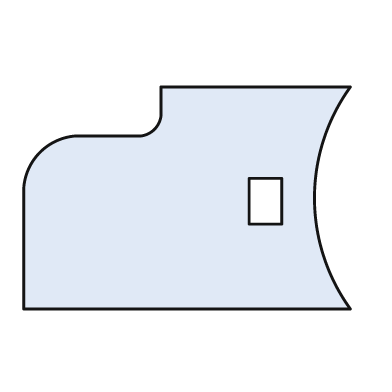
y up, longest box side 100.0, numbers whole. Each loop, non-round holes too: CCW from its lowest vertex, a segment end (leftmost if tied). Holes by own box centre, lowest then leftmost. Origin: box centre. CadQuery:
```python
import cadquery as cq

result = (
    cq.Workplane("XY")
    .moveTo(-50.0, -34.0)
    .lineTo(50.0, -34.0)
    .threePointArc((39.0, 0.0), (50.0, 34.0))
    .lineTo(-8.0, 34.0)
    .lineTo(-8.0, 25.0)
    .threePointArc((-10.0, 21.0), (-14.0, 19.0))
    .lineTo(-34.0, 19.0)
    .threePointArc((-45.0, 14.0), (-50.0, 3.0))
    .close()
    .moveTo(19.0, -8.0)
    .lineTo(29.0, -8.0)
    .lineTo(29.0, 6.0)
    .lineTo(19.0, 6.0)
    .close()
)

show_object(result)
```